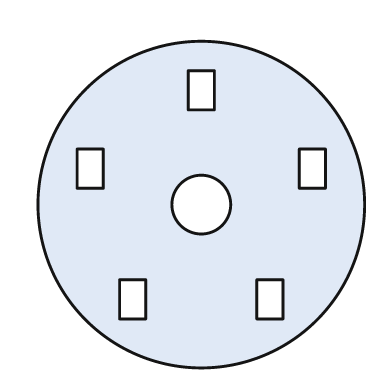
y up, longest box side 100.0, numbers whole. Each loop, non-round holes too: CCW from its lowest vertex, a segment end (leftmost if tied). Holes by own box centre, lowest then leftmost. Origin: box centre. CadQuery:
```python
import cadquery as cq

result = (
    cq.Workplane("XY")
    .moveTo(0.0, 0.0)
    .circle(50.0)
    .moveTo(-25.0, -35.0)
    .lineTo(-17.0, -35.0)
    .lineTo(-17.0, -23.0)
    .lineTo(-25.0, -23.0)
    .close()
    .moveTo(17.0, -35.0)
    .lineTo(25.0, -35.0)
    .lineTo(25.0, -23.0)
    .lineTo(17.0, -23.0)
    .close()
    .moveTo(0.0, 0.0)
    .circle(9.0)
    .moveTo(-38.0, 5.0)
    .lineTo(-30.0, 5.0)
    .lineTo(-30.0, 17.0)
    .lineTo(-38.0, 17.0)
    .close()
    .moveTo(30.0, 5.0)
    .lineTo(38.0, 5.0)
    .lineTo(38.0, 17.0)
    .lineTo(30.0, 17.0)
    .close()
    .moveTo(-4.0, 29.0)
    .lineTo(4.0, 29.0)
    .lineTo(4.0, 41.0)
    .lineTo(-4.0, 41.0)
    .close()
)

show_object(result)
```